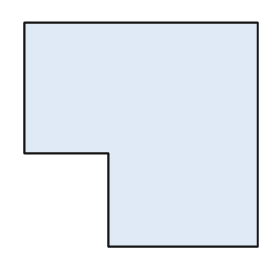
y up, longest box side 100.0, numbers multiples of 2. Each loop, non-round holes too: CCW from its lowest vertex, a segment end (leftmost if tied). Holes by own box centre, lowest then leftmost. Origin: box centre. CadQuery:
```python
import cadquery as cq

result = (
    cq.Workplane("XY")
    .moveTo(-14.0, -48.0)
    .lineTo(50.0, -48.0)
    .lineTo(50.0, 48.0)
    .lineTo(-50.0, 48.0)
    .lineTo(-50.0, -8.0)
    .lineTo(-14.0, -8.0)
    .close()
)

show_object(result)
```